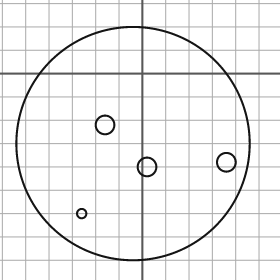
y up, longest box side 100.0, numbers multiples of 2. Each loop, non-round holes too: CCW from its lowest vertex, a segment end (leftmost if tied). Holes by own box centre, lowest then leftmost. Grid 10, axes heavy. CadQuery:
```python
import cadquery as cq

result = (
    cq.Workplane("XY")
    .moveTo(-4.0, -30.0)
    .circle(50.0)
    .moveTo(-26.0, -60.0)
    .circle(2.0)
    .moveTo(2.0, -40.0)
    .circle(4.0)
    .moveTo(36.0, -38.0)
    .circle(4.0)
    .moveTo(-16.0, -22.0)
    .circle(4.0)
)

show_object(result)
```